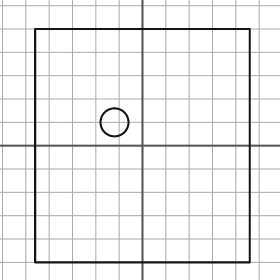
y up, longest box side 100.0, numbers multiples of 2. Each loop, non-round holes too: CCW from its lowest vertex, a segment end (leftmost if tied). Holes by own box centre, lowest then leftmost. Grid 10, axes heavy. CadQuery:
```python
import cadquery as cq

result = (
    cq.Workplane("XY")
    .moveTo(-46.0, -50.0)
    .lineTo(46.0, -50.0)
    .lineTo(46.0, 50.0)
    .lineTo(-46.0, 50.0)
    .close()
    .moveTo(-12.0, 10.0)
    .circle(6.0)
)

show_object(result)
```